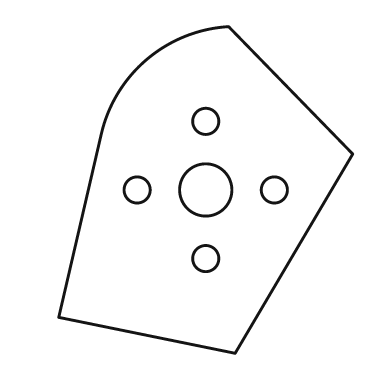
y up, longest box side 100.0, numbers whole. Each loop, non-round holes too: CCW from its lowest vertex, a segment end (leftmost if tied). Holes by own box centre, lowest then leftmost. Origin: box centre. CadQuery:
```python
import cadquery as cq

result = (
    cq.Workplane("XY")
    .moveTo(9.0, -50.0)
    .lineTo(45.0, 11.0)
    .lineTo(7.0, 50.0)
    .threePointArc((-18.0, 40.0), (-32.0, 17.0))
    .lineTo(-45.0, -39.0)
    .close()
    .moveTo(0.0, -21.0)
    .circle(4.0)
    .moveTo(-21.0, 0.0)
    .circle(4.0)
    .moveTo(0.0, 0.0)
    .circle(8.0)
    .moveTo(21.0, 0.0)
    .circle(4.0)
    .moveTo(0.0, 21.0)
    .circle(4.0)
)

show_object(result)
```